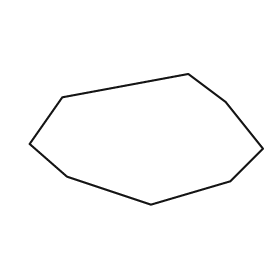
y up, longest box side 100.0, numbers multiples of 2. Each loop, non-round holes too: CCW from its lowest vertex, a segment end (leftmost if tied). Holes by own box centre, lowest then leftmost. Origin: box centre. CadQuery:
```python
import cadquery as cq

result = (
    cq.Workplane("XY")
    .moveTo(2.0, -28.0)
    .lineTo(36.0, -18.0)
    .lineTo(50.0, -4.0)
    .lineTo(34.0, 16.0)
    .lineTo(18.0, 28.0)
    .lineTo(-36.0, 18.0)
    .lineTo(-50.0, -2.0)
    .lineTo(-34.0, -16.0)
    .close()
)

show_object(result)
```